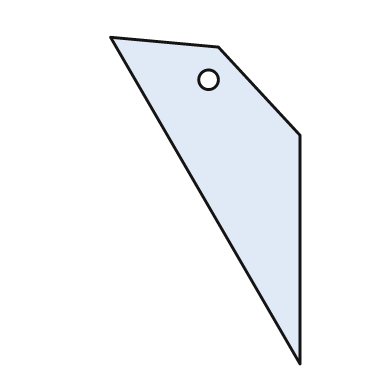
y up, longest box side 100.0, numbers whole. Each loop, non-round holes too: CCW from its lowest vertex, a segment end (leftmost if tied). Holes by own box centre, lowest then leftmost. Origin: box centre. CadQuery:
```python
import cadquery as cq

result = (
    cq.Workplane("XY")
    .moveTo(29.0, -50.0)
    .lineTo(29.0, 20.0)
    .lineTo(4.0, 47.0)
    .lineTo(-29.0, 50.0)
    .close()
    .moveTo(1.0, 37.0)
    .circle(3.0)
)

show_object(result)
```